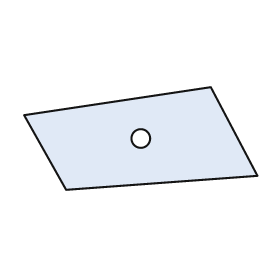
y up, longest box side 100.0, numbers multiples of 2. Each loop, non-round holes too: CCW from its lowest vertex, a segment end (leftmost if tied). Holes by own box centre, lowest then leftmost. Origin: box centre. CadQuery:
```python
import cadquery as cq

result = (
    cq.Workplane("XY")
    .moveTo(-32.0, -22.0)
    .lineTo(50.0, -16.0)
    .lineTo(30.0, 22.0)
    .lineTo(-50.0, 10.0)
    .close()
    .moveTo(0.0, 0.0)
    .circle(4.0)
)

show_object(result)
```